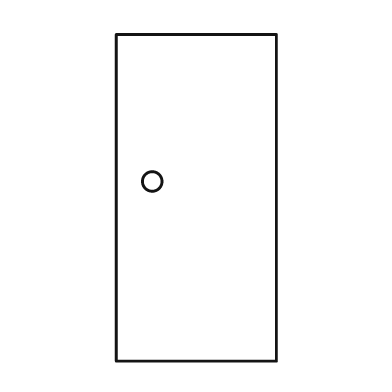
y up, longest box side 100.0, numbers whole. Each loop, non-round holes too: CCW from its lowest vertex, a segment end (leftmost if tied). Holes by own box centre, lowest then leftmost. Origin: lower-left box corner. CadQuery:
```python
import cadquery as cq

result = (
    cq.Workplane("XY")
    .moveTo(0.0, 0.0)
    .lineTo(49.0, 0.0)
    .lineTo(49.0, 100.0)
    .lineTo(0.0, 100.0)
    .close()
    .moveTo(11.0, 55.0)
    .circle(3.0)
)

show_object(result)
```